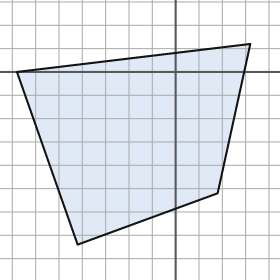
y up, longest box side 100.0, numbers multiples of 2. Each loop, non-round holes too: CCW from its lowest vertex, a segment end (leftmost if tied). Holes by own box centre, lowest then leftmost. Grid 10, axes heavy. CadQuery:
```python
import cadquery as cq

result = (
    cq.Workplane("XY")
    .moveTo(-42.0, -74.0)
    .lineTo(18.0, -52.0)
    .lineTo(32.0, 12.0)
    .lineTo(-68.0, 0.0)
    .close()
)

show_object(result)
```